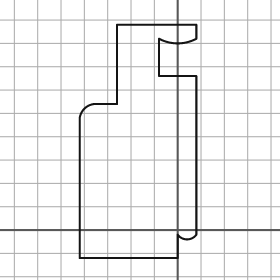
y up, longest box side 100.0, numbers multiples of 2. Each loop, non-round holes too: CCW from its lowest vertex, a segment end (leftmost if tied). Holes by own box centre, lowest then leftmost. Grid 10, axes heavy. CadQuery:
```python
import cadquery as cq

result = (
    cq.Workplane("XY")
    .moveTo(-42.0, -12.0)
    .lineTo(0.0, -12.0)
    .lineTo(0.0, -2.0)
    .threePointArc((4.0, -4.0), (8.0, -2.0))
    .lineTo(8.0, 66.0)
    .lineTo(-8.0, 66.0)
    .lineTo(-8.0, 82.0)
    .threePointArc((0.0, 80.0), (8.0, 82.0))
    .lineTo(8.0, 88.0)
    .lineTo(-26.0, 88.0)
    .lineTo(-26.0, 54.0)
    .lineTo(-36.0, 54.0)
    .threePointArc((-40.0, 52.0), (-42.0, 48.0))
    .close()
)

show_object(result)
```